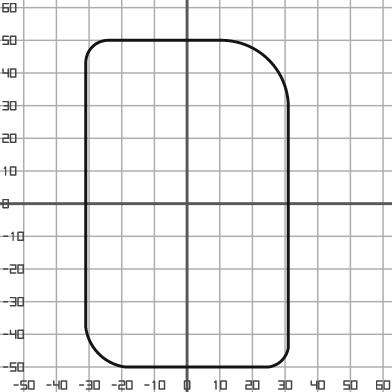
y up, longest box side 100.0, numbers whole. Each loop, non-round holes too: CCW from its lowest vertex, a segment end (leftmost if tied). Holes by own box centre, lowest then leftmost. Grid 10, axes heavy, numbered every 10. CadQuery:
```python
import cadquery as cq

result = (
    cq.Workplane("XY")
    .moveTo(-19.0, -50.0)
    .lineTo(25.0, -50.0)
    .threePointArc((29.0, -48.0), (31.0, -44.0))
    .lineTo(31.0, 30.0)
    .threePointArc((25.0, 44.0), (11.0, 50.0))
    .lineTo(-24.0, 50.0)
    .threePointArc((-29.0, 48.0), (-31.0, 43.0))
    .lineTo(-31.0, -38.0)
    .threePointArc((-27.0, -46.0), (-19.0, -50.0))
    .close()
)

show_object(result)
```